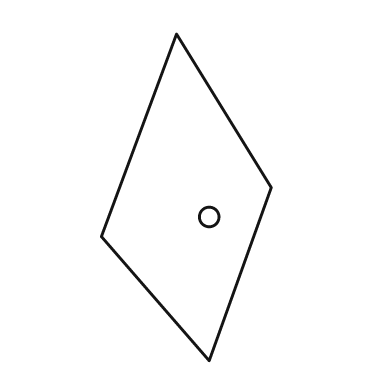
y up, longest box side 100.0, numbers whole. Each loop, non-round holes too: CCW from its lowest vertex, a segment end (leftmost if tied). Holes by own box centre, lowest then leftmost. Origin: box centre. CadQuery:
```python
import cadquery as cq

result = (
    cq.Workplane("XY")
    .moveTo(7.0, -50.0)
    .lineTo(26.0, 3.0)
    .lineTo(-3.0, 50.0)
    .lineTo(-26.0, -12.0)
    .close()
    .moveTo(7.0, -6.0)
    .circle(3.0)
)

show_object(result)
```